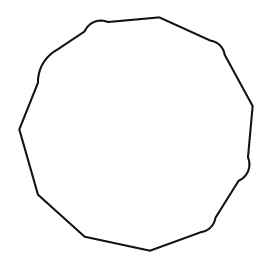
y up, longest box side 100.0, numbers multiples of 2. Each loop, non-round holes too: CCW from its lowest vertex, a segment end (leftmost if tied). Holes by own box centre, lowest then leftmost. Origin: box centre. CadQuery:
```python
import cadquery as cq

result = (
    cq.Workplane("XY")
    .moveTo(6.0, -50.0)
    .lineTo(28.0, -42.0)
    .threePointArc((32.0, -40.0), (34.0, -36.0))
    .lineTo(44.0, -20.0)
    .threePointArc((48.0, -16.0), (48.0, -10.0))
    .lineTo(50.0, 12.0)
    .lineTo(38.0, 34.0)
    .threePointArc((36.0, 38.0), (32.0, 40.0))
    .lineTo(10.0, 50.0)
    .lineTo(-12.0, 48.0)
    .threePointArc((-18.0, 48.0), (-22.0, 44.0))
    .lineTo(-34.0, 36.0)
    .threePointArc((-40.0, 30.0), (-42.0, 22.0))
    .lineTo(-50.0, 2.0)
    .lineTo(-42.0, -26.0)
    .lineTo(-22.0, -44.0)
    .close()
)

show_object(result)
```